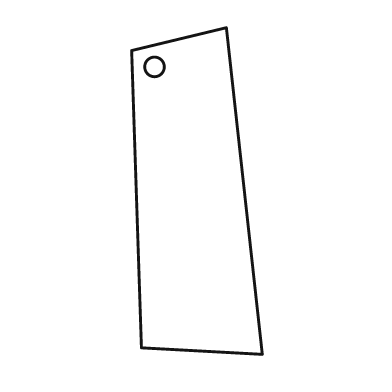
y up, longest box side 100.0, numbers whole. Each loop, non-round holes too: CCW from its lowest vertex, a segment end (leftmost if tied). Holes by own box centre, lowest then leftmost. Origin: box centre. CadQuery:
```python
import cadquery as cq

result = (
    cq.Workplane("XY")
    .moveTo(20.0, -50.0)
    .lineTo(9.0, 50.0)
    .lineTo(-20.0, 43.0)
    .lineTo(-17.0, -48.0)
    .close()
    .moveTo(-13.0, 38.0)
    .circle(3.0)
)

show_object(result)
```